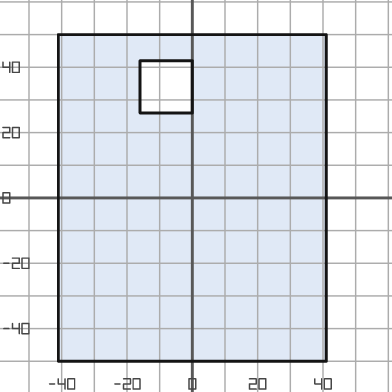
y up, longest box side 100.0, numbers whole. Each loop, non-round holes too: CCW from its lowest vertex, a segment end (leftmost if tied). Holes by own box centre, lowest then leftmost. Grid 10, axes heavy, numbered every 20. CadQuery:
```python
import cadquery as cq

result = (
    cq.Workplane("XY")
    .moveTo(-41.0, -50.0)
    .lineTo(41.0, -50.0)
    .lineTo(41.0, 50.0)
    .lineTo(-41.0, 50.0)
    .close()
    .moveTo(-16.0, 26.0)
    .lineTo(0.0, 26.0)
    .lineTo(0.0, 42.0)
    .lineTo(-16.0, 42.0)
    .close()
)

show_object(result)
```